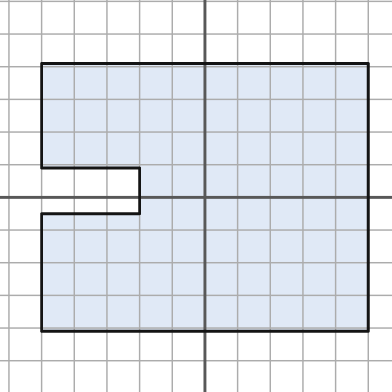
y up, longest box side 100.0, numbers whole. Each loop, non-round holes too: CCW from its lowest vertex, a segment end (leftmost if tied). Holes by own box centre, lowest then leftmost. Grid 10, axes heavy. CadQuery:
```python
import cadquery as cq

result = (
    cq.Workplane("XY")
    .moveTo(-50.0, -41.0)
    .lineTo(50.0, -41.0)
    .lineTo(50.0, 41.0)
    .lineTo(-50.0, 41.0)
    .lineTo(-50.0, 9.0)
    .lineTo(-20.0, 9.0)
    .lineTo(-20.0, -5.0)
    .lineTo(-50.0, -5.0)
    .close()
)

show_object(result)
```